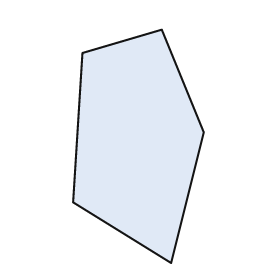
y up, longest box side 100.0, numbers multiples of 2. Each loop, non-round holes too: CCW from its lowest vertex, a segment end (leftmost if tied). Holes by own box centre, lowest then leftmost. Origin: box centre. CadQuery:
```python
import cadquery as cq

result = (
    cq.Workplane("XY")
    .moveTo(14.0, -50.0)
    .lineTo(28.0, 6.0)
    .lineTo(10.0, 50.0)
    .lineTo(-24.0, 40.0)
    .lineTo(-28.0, -24.0)
    .close()
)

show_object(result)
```